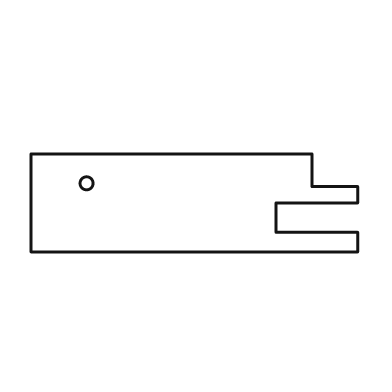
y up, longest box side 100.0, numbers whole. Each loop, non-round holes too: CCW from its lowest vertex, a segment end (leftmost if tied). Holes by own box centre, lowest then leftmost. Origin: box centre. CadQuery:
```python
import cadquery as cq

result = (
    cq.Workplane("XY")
    .moveTo(-50.0, -15.0)
    .lineTo(50.0, -15.0)
    .lineTo(50.0, -9.0)
    .lineTo(25.0, -9.0)
    .lineTo(25.0, 0.0)
    .lineTo(50.0, 0.0)
    .lineTo(50.0, 5.0)
    .lineTo(36.0, 5.0)
    .lineTo(36.0, 15.0)
    .lineTo(-50.0, 15.0)
    .close()
    .moveTo(-33.0, 6.0)
    .circle(2.0)
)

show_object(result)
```